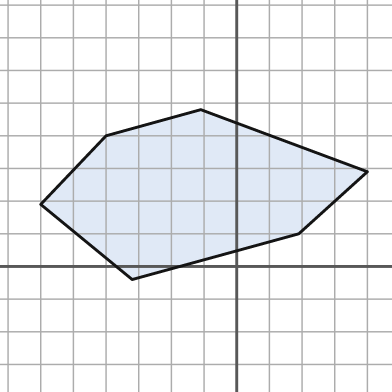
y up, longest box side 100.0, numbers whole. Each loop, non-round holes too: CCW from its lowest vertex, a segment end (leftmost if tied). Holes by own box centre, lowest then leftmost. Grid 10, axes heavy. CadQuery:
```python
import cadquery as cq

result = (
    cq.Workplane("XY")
    .moveTo(-32.0, -4.0)
    .lineTo(19.0, 10.0)
    .lineTo(40.0, 29.0)
    .lineTo(-11.0, 48.0)
    .lineTo(-40.0, 40.0)
    .lineTo(-60.0, 19.0)
    .close()
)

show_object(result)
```